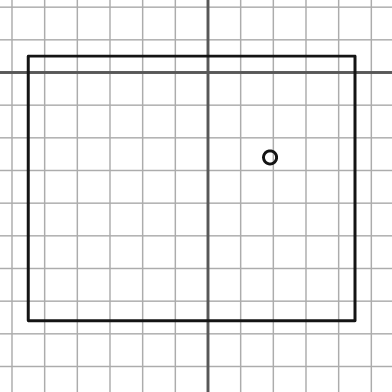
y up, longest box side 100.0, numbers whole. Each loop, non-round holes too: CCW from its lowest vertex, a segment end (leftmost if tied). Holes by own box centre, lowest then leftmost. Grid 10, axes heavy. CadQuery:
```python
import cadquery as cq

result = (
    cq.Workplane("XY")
    .moveTo(-55.0, -76.0)
    .lineTo(45.0, -76.0)
    .lineTo(45.0, 5.0)
    .lineTo(-55.0, 5.0)
    .close()
    .moveTo(19.0, -26.0)
    .circle(2.0)
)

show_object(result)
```